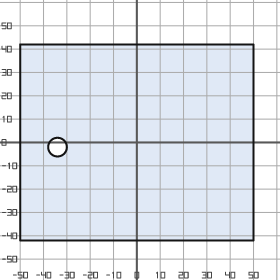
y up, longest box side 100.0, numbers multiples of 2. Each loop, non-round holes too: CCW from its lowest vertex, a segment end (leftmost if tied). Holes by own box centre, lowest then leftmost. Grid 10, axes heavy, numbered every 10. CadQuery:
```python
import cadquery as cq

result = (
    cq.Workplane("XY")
    .moveTo(-50.0, -42.0)
    .lineTo(50.0, -42.0)
    .lineTo(50.0, 42.0)
    .lineTo(-50.0, 42.0)
    .close()
    .moveTo(-34.0, -2.0)
    .circle(4.0)
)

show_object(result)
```